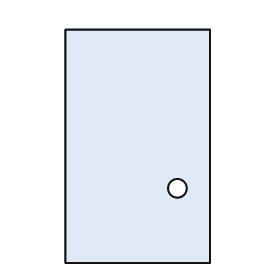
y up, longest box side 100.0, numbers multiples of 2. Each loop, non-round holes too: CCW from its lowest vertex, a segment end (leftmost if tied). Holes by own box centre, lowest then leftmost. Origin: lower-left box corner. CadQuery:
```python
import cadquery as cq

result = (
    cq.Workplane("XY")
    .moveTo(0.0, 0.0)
    .lineTo(62.0, 0.0)
    .lineTo(62.0, 100.0)
    .lineTo(0.0, 100.0)
    .close()
    .moveTo(48.0, 32.0)
    .circle(4.0)
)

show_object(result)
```